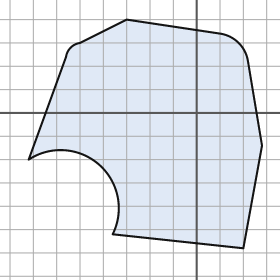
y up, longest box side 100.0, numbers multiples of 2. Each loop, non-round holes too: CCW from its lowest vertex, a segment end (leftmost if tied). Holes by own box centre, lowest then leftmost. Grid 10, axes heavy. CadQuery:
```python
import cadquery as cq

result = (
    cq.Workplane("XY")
    .moveTo(20.0, -58.0)
    .lineTo(28.0, -14.0)
    .lineTo(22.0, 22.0)
    .threePointArc((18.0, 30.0), (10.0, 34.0))
    .lineTo(-30.0, 40.0)
    .lineTo(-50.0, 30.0)
    .threePointArc((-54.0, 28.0), (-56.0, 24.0))
    .lineTo(-72.0, -20.0)
    .threePointArc((-42.0, -22.0), (-36.0, -52.0))
    .close()
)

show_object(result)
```